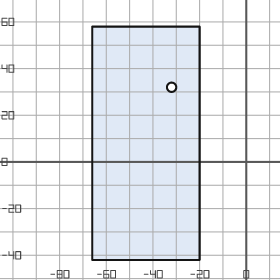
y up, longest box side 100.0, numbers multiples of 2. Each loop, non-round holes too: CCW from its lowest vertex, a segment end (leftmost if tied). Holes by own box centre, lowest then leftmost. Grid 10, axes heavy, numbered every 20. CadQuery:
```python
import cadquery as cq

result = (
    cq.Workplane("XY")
    .moveTo(-66.0, -42.0)
    .lineTo(-20.0, -42.0)
    .lineTo(-20.0, 58.0)
    .lineTo(-66.0, 58.0)
    .close()
    .moveTo(-32.0, 32.0)
    .circle(2.0)
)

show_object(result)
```